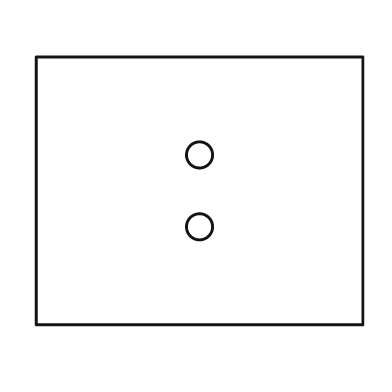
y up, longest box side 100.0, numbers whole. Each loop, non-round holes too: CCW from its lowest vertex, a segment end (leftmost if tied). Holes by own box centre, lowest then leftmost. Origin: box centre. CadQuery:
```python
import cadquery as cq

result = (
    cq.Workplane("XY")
    .moveTo(-50.0, -41.0)
    .lineTo(50.0, -41.0)
    .lineTo(50.0, 41.0)
    .lineTo(-50.0, 41.0)
    .close()
    .moveTo(0.0, -11.0)
    .circle(4.0)
    .moveTo(0.0, 11.0)
    .circle(4.0)
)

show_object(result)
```